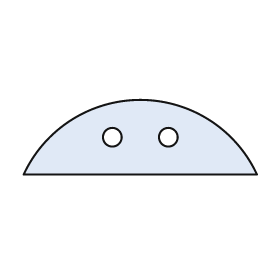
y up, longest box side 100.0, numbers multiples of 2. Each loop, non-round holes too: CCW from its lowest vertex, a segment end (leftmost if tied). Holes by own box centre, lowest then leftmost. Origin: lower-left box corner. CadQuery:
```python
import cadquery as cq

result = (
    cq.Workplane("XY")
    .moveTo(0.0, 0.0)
    .lineTo(100.0, 0.0)
    .threePointArc((50.0, 32.0), (0.0, 0.0))
    .close()
    .moveTo(38.0, 16.0)
    .circle(4.0)
    .moveTo(62.0, 16.0)
    .circle(4.0)
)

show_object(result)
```